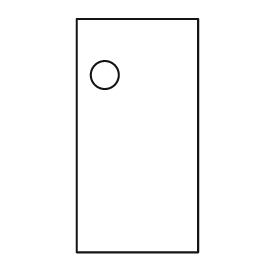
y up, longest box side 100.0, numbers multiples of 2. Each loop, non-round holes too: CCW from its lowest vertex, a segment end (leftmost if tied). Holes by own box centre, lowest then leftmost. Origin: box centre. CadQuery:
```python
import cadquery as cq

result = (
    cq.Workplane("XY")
    .moveTo(-26.0, -50.0)
    .lineTo(26.0, -50.0)
    .lineTo(26.0, 50.0)
    .lineTo(-26.0, 50.0)
    .close()
    .moveTo(-14.0, 26.0)
    .circle(6.0)
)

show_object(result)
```